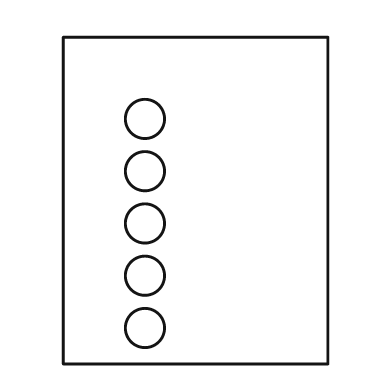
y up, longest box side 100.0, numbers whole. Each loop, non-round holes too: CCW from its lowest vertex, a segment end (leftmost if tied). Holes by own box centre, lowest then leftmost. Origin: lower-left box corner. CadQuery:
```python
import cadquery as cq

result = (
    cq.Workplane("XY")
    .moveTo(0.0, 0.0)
    .lineTo(81.0, 0.0)
    .lineTo(81.0, 100.0)
    .lineTo(0.0, 100.0)
    .close()
    .moveTo(25.0, 11.0)
    .circle(6.0)
    .moveTo(25.0, 27.0)
    .circle(6.0)
    .moveTo(25.0, 43.0)
    .circle(6.0)
    .moveTo(25.0, 59.0)
    .circle(6.0)
    .moveTo(25.0, 75.0)
    .circle(6.0)
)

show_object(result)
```